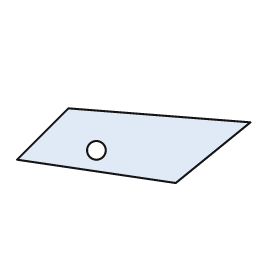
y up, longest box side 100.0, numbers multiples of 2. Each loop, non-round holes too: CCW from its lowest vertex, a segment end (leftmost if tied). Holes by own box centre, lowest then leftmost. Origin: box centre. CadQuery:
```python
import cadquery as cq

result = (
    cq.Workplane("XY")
    .moveTo(18.0, -16.0)
    .lineTo(50.0, 10.0)
    .lineTo(-28.0, 16.0)
    .lineTo(-50.0, -6.0)
    .close()
    .moveTo(-16.0, -2.0)
    .circle(4.0)
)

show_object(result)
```